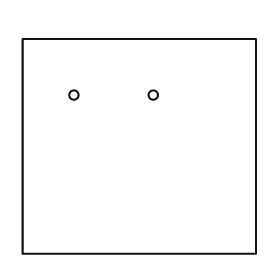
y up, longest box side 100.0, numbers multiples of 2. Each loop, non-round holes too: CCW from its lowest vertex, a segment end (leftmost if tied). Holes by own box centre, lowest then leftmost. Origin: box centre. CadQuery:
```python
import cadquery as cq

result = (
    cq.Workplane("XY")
    .moveTo(-50.0, -46.0)
    .lineTo(50.0, -46.0)
    .lineTo(50.0, 46.0)
    .lineTo(-50.0, 46.0)
    .close()
    .moveTo(-28.0, 22.0)
    .circle(2.0)
    .moveTo(6.0, 22.0)
    .circle(2.0)
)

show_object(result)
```